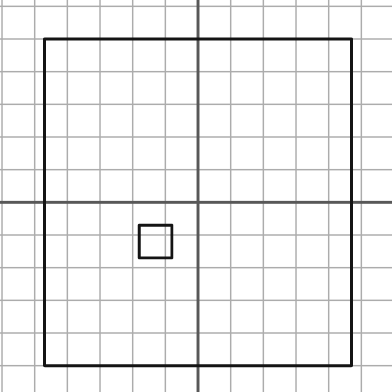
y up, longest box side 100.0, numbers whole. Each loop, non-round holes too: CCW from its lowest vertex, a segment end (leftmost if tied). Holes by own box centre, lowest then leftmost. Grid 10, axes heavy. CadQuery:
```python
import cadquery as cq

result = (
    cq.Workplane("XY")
    .moveTo(-47.0, -50.0)
    .lineTo(47.0, -50.0)
    .lineTo(47.0, 50.0)
    .lineTo(-47.0, 50.0)
    .close()
    .moveTo(-18.0, -17.0)
    .lineTo(-8.0, -17.0)
    .lineTo(-8.0, -7.0)
    .lineTo(-18.0, -7.0)
    .close()
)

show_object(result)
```